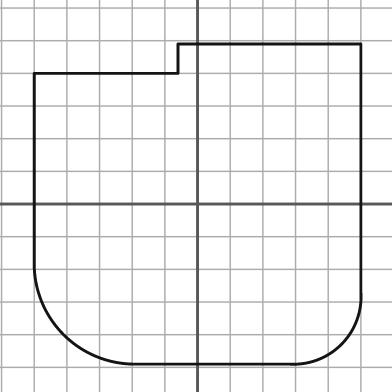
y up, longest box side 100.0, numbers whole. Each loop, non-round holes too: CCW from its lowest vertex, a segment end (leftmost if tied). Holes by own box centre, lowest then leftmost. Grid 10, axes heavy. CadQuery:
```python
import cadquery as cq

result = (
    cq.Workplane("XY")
    .moveTo(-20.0, -49.0)
    .lineTo(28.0, -49.0)
    .threePointArc((44.0, -43.0), (50.0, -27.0))
    .lineTo(50.0, 49.0)
    .lineTo(-6.0, 49.0)
    .lineTo(-6.0, 40.0)
    .lineTo(-50.0, 40.0)
    .lineTo(-50.0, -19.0)
    .threePointArc((-41.0, -40.0), (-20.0, -49.0))
    .close()
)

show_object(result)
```